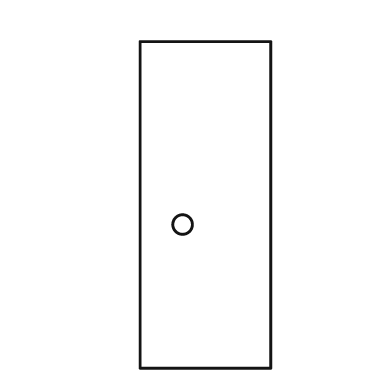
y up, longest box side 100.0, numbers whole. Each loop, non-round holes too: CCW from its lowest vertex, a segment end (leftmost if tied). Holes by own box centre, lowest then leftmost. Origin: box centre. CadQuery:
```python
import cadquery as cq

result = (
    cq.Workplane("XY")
    .moveTo(-20.0, -50.0)
    .lineTo(20.0, -50.0)
    .lineTo(20.0, 50.0)
    .lineTo(-20.0, 50.0)
    .close()
    .moveTo(-7.0, -6.0)
    .circle(3.0)
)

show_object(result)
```